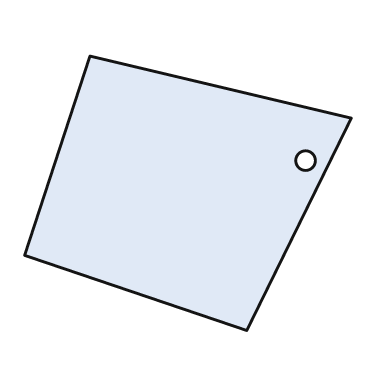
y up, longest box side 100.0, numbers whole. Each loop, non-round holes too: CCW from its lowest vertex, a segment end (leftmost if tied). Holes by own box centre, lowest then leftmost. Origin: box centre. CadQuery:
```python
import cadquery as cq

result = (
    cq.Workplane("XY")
    .moveTo(18.0, -42.0)
    .lineTo(50.0, 23.0)
    .lineTo(-30.0, 42.0)
    .lineTo(-50.0, -19.0)
    .close()
    .moveTo(36.0, 10.0)
    .circle(3.0)
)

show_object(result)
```